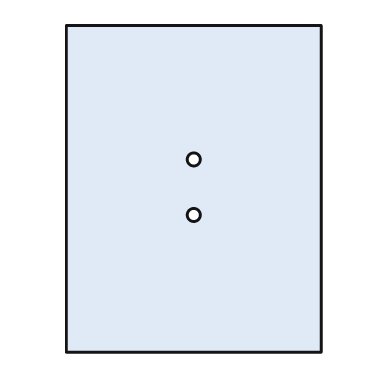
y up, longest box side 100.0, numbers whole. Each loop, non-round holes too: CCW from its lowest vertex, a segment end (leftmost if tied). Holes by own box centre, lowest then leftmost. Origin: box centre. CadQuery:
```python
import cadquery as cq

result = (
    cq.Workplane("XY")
    .moveTo(-39.0, -50.0)
    .lineTo(39.0, -50.0)
    .lineTo(39.0, 50.0)
    .lineTo(-39.0, 50.0)
    .close()
    .moveTo(0.0, -8.0)
    .circle(2.0)
    .moveTo(0.0, 9.0)
    .circle(2.0)
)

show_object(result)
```